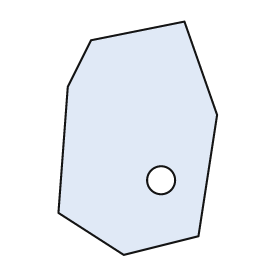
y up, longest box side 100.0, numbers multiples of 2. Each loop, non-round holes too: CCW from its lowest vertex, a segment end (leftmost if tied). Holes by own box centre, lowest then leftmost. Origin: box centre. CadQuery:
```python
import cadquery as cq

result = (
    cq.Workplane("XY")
    .moveTo(-6.0, -50.0)
    .lineTo(26.0, -42.0)
    .lineTo(34.0, 10.0)
    .lineTo(20.0, 50.0)
    .lineTo(-20.0, 42.0)
    .lineTo(-30.0, 22.0)
    .lineTo(-34.0, -32.0)
    .close()
    .moveTo(10.0, -18.0)
    .circle(6.0)
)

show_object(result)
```